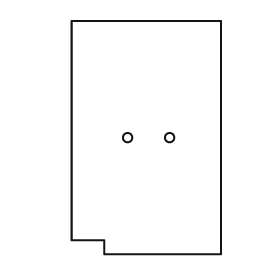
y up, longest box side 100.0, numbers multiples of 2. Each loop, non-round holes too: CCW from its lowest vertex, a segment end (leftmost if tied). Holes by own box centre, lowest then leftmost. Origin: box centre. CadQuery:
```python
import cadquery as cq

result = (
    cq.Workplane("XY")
    .moveTo(-18.0, -50.0)
    .lineTo(32.0, -50.0)
    .lineTo(32.0, 50.0)
    .lineTo(-32.0, 50.0)
    .lineTo(-32.0, -44.0)
    .lineTo(-18.0, -44.0)
    .close()
    .moveTo(-8.0, 0.0)
    .circle(2.0)
    .moveTo(10.0, 0.0)
    .circle(2.0)
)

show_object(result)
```